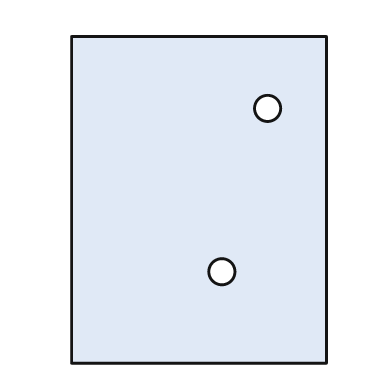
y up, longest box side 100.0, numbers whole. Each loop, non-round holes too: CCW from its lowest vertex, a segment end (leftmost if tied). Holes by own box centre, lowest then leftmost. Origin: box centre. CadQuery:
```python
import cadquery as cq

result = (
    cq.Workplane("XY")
    .moveTo(-39.0, -50.0)
    .lineTo(39.0, -50.0)
    .lineTo(39.0, 50.0)
    .lineTo(-39.0, 50.0)
    .close()
    .moveTo(7.0, -22.0)
    .circle(4.0)
    .moveTo(21.0, 28.0)
    .circle(4.0)
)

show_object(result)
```